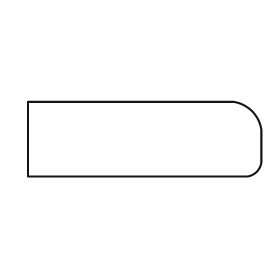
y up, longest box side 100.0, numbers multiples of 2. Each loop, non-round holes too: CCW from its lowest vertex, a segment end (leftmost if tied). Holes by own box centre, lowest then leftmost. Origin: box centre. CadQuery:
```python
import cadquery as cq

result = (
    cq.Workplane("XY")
    .moveTo(-50.0, -16.0)
    .lineTo(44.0, -16.0)
    .threePointArc((48.0, -14.0), (50.0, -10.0))
    .lineTo(50.0, 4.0)
    .threePointArc((46.0, 12.0), (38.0, 16.0))
    .lineTo(-50.0, 16.0)
    .close()
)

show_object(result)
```